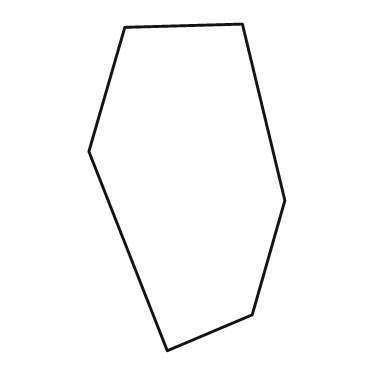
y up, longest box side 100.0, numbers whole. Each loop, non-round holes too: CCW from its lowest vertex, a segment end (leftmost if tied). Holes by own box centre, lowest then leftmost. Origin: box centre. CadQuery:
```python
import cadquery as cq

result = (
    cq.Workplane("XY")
    .moveTo(-6.0, -50.0)
    .lineTo(20.0, -39.0)
    .lineTo(30.0, -4.0)
    .lineTo(17.0, 50.0)
    .lineTo(-19.0, 49.0)
    .lineTo(-30.0, 11.0)
    .close()
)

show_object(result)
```